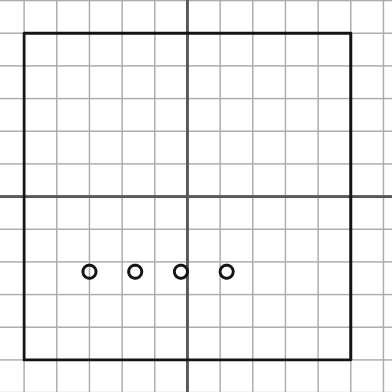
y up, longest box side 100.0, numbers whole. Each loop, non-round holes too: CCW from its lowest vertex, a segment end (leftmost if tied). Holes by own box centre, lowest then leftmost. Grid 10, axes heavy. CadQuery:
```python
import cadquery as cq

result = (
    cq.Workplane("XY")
    .moveTo(-50.0, -50.0)
    .lineTo(50.0, -50.0)
    .lineTo(50.0, 50.0)
    .lineTo(-50.0, 50.0)
    .close()
    .moveTo(-30.0, -23.0)
    .circle(2.0)
    .moveTo(-16.0, -23.0)
    .circle(2.0)
    .moveTo(-2.0, -23.0)
    .circle(2.0)
    .moveTo(12.0, -23.0)
    .circle(2.0)
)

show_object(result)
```